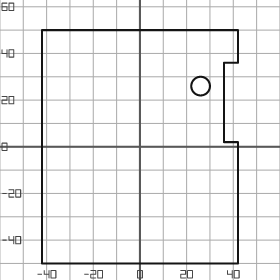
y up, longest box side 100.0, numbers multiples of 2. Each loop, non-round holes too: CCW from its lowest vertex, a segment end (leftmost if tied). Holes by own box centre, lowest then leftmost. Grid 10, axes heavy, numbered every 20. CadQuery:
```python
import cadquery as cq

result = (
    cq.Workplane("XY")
    .moveTo(-42.0, -50.0)
    .lineTo(42.0, -50.0)
    .lineTo(42.0, 2.0)
    .lineTo(36.0, 2.0)
    .lineTo(36.0, 36.0)
    .lineTo(42.0, 36.0)
    .lineTo(42.0, 50.0)
    .lineTo(-42.0, 50.0)
    .close()
    .moveTo(26.0, 26.0)
    .circle(4.0)
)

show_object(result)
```